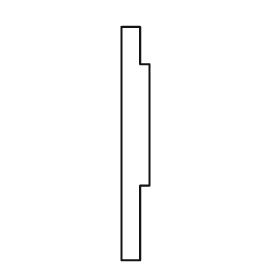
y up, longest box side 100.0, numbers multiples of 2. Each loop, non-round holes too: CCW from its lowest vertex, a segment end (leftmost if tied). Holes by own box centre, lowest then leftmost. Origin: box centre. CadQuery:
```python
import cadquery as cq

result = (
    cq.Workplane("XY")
    .moveTo(-6.0, -50.0)
    .lineTo(2.0, -50.0)
    .lineTo(2.0, -18.0)
    .lineTo(6.0, -18.0)
    .lineTo(6.0, 34.0)
    .lineTo(2.0, 34.0)
    .lineTo(2.0, 50.0)
    .lineTo(-6.0, 50.0)
    .close()
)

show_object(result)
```